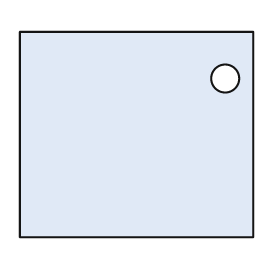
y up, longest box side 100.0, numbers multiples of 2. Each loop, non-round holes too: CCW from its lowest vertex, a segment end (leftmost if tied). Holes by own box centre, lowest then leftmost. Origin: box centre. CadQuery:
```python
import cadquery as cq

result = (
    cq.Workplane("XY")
    .moveTo(-50.0, -44.0)
    .lineTo(50.0, -44.0)
    .lineTo(50.0, 44.0)
    .lineTo(-50.0, 44.0)
    .close()
    .moveTo(38.0, 24.0)
    .circle(6.0)
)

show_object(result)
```